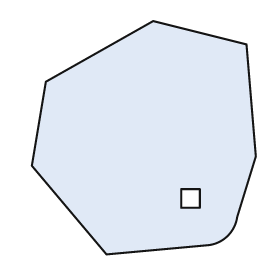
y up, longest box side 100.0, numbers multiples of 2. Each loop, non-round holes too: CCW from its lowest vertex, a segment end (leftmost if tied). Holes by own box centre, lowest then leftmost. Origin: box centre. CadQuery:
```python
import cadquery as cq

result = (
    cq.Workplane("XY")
    .moveTo(-16.0, -50.0)
    .lineTo(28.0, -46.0)
    .threePointArc((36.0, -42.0), (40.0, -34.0))
    .lineTo(48.0, -8.0)
    .lineTo(44.0, 40.0)
    .lineTo(4.0, 50.0)
    .lineTo(-42.0, 24.0)
    .lineTo(-48.0, -12.0)
    .close()
    .moveTo(16.0, -30.0)
    .lineTo(24.0, -30.0)
    .lineTo(24.0, -22.0)
    .lineTo(16.0, -22.0)
    .close()
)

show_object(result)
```